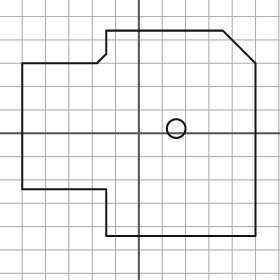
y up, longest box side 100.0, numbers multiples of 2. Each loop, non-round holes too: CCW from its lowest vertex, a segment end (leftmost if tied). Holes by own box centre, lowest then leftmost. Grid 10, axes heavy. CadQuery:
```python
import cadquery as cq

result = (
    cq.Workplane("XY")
    .moveTo(-14.0, -44.0)
    .lineTo(50.0, -44.0)
    .lineTo(50.0, 30.0)
    .lineTo(36.0, 44.0)
    .lineTo(-14.0, 44.0)
    .lineTo(-14.0, 34.0)
    .lineTo(-18.0, 30.0)
    .lineTo(-50.0, 30.0)
    .lineTo(-50.0, -24.0)
    .lineTo(-14.0, -24.0)
    .close()
    .moveTo(16.0, 2.0)
    .circle(4.0)
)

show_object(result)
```